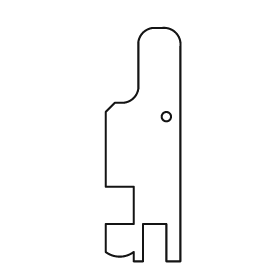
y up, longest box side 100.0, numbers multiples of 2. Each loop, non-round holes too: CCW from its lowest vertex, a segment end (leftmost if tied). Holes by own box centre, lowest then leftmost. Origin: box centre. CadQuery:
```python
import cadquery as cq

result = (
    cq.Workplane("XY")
    .moveTo(-4.0, -50.0)
    .lineTo(0.0, -50.0)
    .lineTo(0.0, -34.0)
    .lineTo(10.0, -34.0)
    .lineTo(10.0, -50.0)
    .lineTo(16.0, -50.0)
    .lineTo(16.0, 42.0)
    .threePointArc((14.0, 48.0), (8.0, 50.0))
    .lineTo(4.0, 50.0)
    .threePointArc((0.0, 48.0), (-2.0, 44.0))
    .lineTo(-2.0, 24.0)
    .threePointArc((-4.0, 20.0), (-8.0, 18.0))
    .lineTo(-12.0, 18.0)
    .lineTo(-16.0, 14.0)
    .lineTo(-16.0, -18.0)
    .lineTo(-4.0, -18.0)
    .lineTo(-4.0, -34.0)
    .lineTo(-16.0, -34.0)
    .lineTo(-16.0, -46.0)
    .threePointArc((-10.0, -48.0), (-4.0, -46.0))
    .close()
    .moveTo(10.0, 12.0)
    .circle(2.0)
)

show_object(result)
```